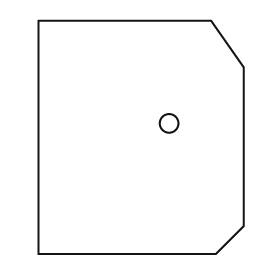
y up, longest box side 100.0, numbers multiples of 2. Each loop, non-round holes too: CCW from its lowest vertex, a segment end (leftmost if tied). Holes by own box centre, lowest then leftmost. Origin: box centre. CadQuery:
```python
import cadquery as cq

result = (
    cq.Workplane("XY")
    .moveTo(-44.0, -50.0)
    .lineTo(32.0, -50.0)
    .lineTo(44.0, -38.0)
    .lineTo(44.0, 30.0)
    .lineTo(30.0, 50.0)
    .lineTo(-44.0, 50.0)
    .close()
    .moveTo(12.0, 6.0)
    .circle(4.0)
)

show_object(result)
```